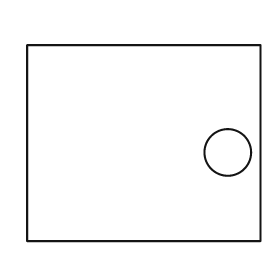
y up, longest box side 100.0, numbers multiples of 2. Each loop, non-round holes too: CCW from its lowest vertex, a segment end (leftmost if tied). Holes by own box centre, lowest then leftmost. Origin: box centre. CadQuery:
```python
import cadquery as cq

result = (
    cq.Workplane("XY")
    .moveTo(-50.0, -42.0)
    .lineTo(50.0, -42.0)
    .lineTo(50.0, 42.0)
    .lineTo(-50.0, 42.0)
    .close()
    .moveTo(36.0, -4.0)
    .circle(10.0)
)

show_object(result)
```